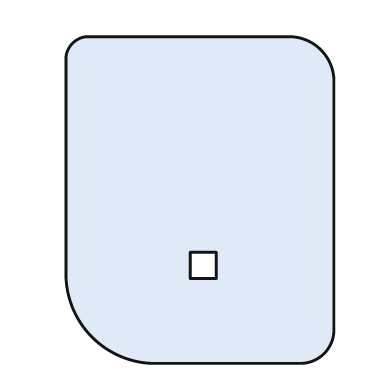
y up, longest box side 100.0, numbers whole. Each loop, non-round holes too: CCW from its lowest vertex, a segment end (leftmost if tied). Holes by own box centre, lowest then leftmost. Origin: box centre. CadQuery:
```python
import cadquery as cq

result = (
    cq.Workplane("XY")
    .moveTo(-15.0, -50.0)
    .lineTo(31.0, -50.0)
    .threePointArc((38.0, -47.0), (41.0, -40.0))
    .lineTo(41.0, 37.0)
    .threePointArc((37.0, 46.0), (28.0, 50.0))
    .lineTo(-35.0, 50.0)
    .threePointArc((-39.0, 48.0), (-41.0, 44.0))
    .lineTo(-41.0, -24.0)
    .threePointArc((-33.0, -42.0), (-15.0, -50.0))
    .close()
    .moveTo(-3.0, -24.0)
    .lineTo(5.0, -24.0)
    .lineTo(5.0, -16.0)
    .lineTo(-3.0, -16.0)
    .close()
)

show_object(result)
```